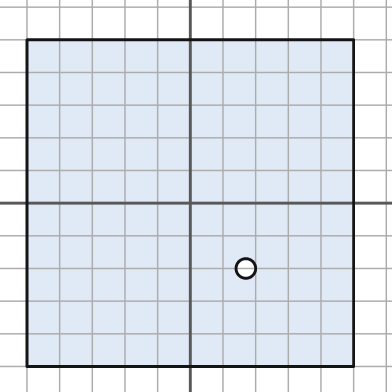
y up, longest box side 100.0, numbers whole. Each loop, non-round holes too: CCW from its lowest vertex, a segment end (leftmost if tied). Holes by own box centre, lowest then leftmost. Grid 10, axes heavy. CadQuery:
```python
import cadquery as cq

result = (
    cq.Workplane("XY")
    .moveTo(-50.0, -50.0)
    .lineTo(50.0, -50.0)
    .lineTo(50.0, 50.0)
    .lineTo(-50.0, 50.0)
    .close()
    .moveTo(17.0, -20.0)
    .circle(3.0)
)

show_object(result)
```